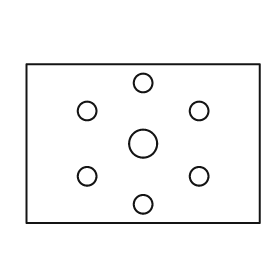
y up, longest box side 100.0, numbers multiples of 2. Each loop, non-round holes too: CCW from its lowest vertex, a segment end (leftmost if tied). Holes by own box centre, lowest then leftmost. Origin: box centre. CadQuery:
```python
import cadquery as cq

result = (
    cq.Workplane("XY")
    .moveTo(-50.0, -34.0)
    .lineTo(50.0, -34.0)
    .lineTo(50.0, 34.0)
    .lineTo(-50.0, 34.0)
    .close()
    .moveTo(0.0, -26.0)
    .circle(4.0)
    .moveTo(-24.0, -14.0)
    .circle(4.0)
    .moveTo(24.0, -14.0)
    .circle(4.0)
    .moveTo(0.0, 0.0)
    .circle(6.0)
    .moveTo(-24.0, 14.0)
    .circle(4.0)
    .moveTo(24.0, 14.0)
    .circle(4.0)
    .moveTo(0.0, 26.0)
    .circle(4.0)
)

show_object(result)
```